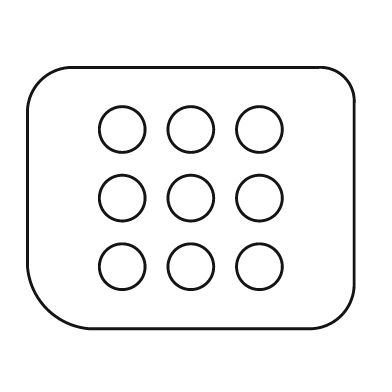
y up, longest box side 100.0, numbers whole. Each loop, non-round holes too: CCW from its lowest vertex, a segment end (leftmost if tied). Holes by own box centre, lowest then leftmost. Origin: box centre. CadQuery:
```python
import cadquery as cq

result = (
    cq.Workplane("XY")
    .moveTo(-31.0, -40.0)
    .lineTo(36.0, -40.0)
    .threePointArc((46.0, -36.0), (50.0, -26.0))
    .lineTo(50.0, 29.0)
    .threePointArc((47.0, 37.0), (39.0, 40.0))
    .lineTo(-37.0, 40.0)
    .threePointArc((-46.0, 36.0), (-50.0, 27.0))
    .lineTo(-50.0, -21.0)
    .threePointArc((-44.0, -34.0), (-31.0, -40.0))
    .close()
    .moveTo(-21.0, -21.0)
    .circle(7.0)
    .moveTo(0.0, -21.0)
    .circle(7.0)
    .moveTo(21.0, -21.0)
    .circle(7.0)
    .moveTo(-21.0, 0.0)
    .circle(7.0)
    .moveTo(0.0, 0.0)
    .circle(7.0)
    .moveTo(21.0, 0.0)
    .circle(7.0)
    .moveTo(-21.0, 21.0)
    .circle(7.0)
    .moveTo(0.0, 21.0)
    .circle(7.0)
    .moveTo(21.0, 21.0)
    .circle(7.0)
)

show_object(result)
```